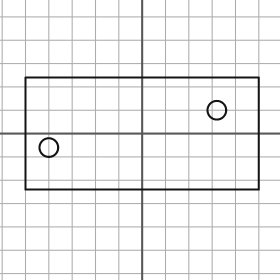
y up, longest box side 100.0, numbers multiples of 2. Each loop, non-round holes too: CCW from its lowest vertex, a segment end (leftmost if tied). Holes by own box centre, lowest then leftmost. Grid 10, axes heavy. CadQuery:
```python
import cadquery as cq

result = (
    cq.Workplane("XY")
    .moveTo(-50.0, -24.0)
    .lineTo(50.0, -24.0)
    .lineTo(50.0, 24.0)
    .lineTo(-50.0, 24.0)
    .close()
    .moveTo(-40.0, -6.0)
    .circle(4.0)
    .moveTo(32.0, 10.0)
    .circle(4.0)
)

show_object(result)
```